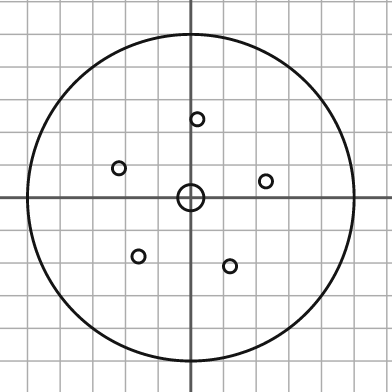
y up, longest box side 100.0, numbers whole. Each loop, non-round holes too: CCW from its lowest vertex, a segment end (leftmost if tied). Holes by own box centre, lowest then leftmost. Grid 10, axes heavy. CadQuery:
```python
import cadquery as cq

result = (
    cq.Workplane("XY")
    .moveTo(0.0, 0.0)
    .circle(50.0)
    .moveTo(12.0, -21.0)
    .circle(2.0)
    .moveTo(-16.0, -18.0)
    .circle(2.0)
    .moveTo(0.0, 0.0)
    .circle(4.0)
    .moveTo(23.0, 5.0)
    .circle(2.0)
    .moveTo(-22.0, 9.0)
    .circle(2.0)
    .moveTo(2.0, 24.0)
    .circle(2.0)
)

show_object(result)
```